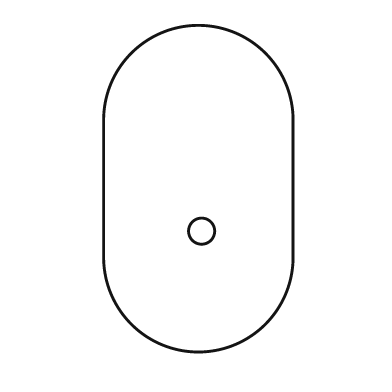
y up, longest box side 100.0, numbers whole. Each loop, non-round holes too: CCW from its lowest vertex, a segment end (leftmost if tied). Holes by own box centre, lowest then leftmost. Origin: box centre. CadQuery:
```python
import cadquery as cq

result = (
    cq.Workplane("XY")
    .moveTo(-29.0, -21.0)
    .threePointArc((0.0, -50.0), (29.0, -21.0))
    .lineTo(29.0, 21.0)
    .threePointArc((0.0, 50.0), (-29.0, 21.0))
    .close()
    .moveTo(1.0, -13.0)
    .circle(4.0)
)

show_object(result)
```